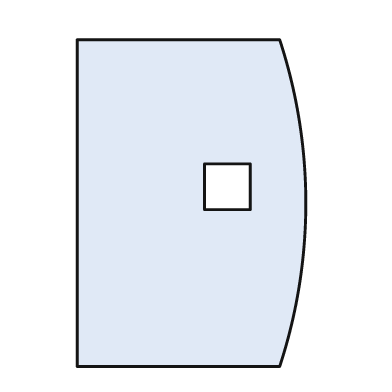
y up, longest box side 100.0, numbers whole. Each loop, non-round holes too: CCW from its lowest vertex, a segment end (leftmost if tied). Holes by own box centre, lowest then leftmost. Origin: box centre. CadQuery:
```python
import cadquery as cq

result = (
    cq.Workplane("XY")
    .moveTo(-35.0, -50.0)
    .lineTo(27.0, -50.0)
    .threePointArc((35.0, 0.0), (27.0, 50.0))
    .lineTo(-35.0, 50.0)
    .close()
    .moveTo(4.0, -2.0)
    .lineTo(18.0, -2.0)
    .lineTo(18.0, 12.0)
    .lineTo(4.0, 12.0)
    .close()
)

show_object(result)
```